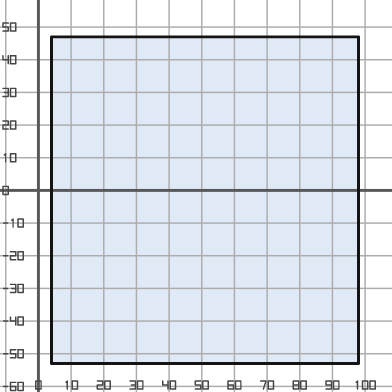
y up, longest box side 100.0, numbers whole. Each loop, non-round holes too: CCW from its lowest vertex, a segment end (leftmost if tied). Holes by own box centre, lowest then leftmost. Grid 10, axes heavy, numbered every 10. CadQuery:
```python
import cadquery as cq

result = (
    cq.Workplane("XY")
    .moveTo(4.0, -53.0)
    .lineTo(98.0, -53.0)
    .lineTo(98.0, 47.0)
    .lineTo(4.0, 47.0)
    .close()
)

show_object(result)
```